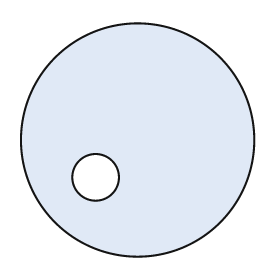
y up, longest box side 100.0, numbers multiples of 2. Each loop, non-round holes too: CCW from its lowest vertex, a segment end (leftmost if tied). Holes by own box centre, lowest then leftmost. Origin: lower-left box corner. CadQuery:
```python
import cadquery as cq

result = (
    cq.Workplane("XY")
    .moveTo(50.0, 50.0)
    .circle(50.0)
    .moveTo(32.0, 34.0)
    .circle(10.0)
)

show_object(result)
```